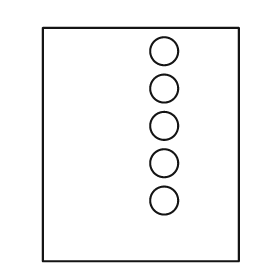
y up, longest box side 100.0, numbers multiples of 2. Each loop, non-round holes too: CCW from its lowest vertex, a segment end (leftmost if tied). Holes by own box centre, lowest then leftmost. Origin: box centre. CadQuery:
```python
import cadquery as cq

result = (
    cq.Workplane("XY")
    .moveTo(-42.0, -50.0)
    .lineTo(42.0, -50.0)
    .lineTo(42.0, 50.0)
    .lineTo(-42.0, 50.0)
    .close()
    .moveTo(10.0, -24.0)
    .circle(6.0)
    .moveTo(10.0, -8.0)
    .circle(6.0)
    .moveTo(10.0, 8.0)
    .circle(6.0)
    .moveTo(10.0, 24.0)
    .circle(6.0)
    .moveTo(10.0, 40.0)
    .circle(6.0)
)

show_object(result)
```